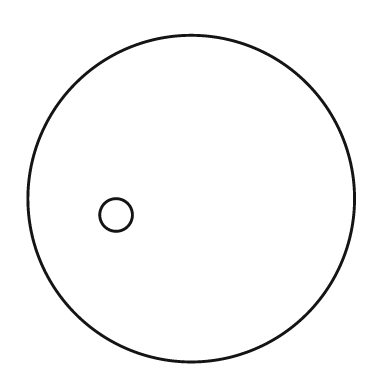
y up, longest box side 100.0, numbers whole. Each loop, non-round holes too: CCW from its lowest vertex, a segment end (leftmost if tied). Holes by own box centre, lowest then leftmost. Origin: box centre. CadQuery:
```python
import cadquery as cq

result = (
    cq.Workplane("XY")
    .moveTo(0.0, 0.0)
    .circle(50.0)
    .moveTo(-23.0, -5.0)
    .circle(5.0)
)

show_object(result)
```